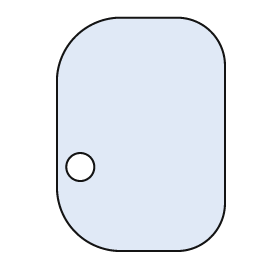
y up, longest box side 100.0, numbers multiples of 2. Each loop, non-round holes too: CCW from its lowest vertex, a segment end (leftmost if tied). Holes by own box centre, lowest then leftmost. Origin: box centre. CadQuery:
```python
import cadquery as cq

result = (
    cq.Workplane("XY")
    .moveTo(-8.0, -50.0)
    .lineTo(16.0, -50.0)
    .threePointArc((30.0, -44.0), (36.0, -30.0))
    .lineTo(36.0, 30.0)
    .threePointArc((30.0, 44.0), (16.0, 50.0))
    .lineTo(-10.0, 50.0)
    .threePointArc((-28.0, 42.0), (-36.0, 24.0))
    .lineTo(-36.0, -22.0)
    .threePointArc((-28.0, -42.0), (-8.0, -50.0))
    .close()
    .moveTo(-26.0, -14.0)
    .circle(6.0)
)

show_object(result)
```